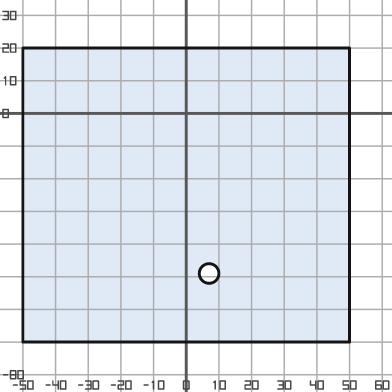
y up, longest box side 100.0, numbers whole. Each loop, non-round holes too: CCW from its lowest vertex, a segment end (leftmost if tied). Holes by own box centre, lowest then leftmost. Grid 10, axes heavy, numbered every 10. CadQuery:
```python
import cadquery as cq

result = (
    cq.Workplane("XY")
    .moveTo(-50.0, -70.0)
    .lineTo(50.0, -70.0)
    .lineTo(50.0, 20.0)
    .lineTo(-50.0, 20.0)
    .close()
    .moveTo(7.0, -49.0)
    .circle(3.0)
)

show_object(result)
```